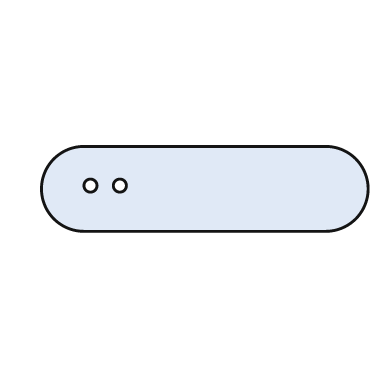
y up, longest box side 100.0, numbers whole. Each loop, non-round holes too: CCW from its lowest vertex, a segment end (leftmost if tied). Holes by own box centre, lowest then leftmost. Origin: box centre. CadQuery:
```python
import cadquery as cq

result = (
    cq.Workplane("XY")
    .moveTo(-37.0, -13.0)
    .lineTo(37.0, -13.0)
    .threePointArc((50.0, 0.0), (37.0, 13.0))
    .lineTo(-37.0, 13.0)
    .threePointArc((-50.0, 0.0), (-37.0, -13.0))
    .close()
    .moveTo(-35.0, 1.0)
    .circle(2.0)
    .moveTo(-26.0, 1.0)
    .circle(2.0)
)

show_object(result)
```